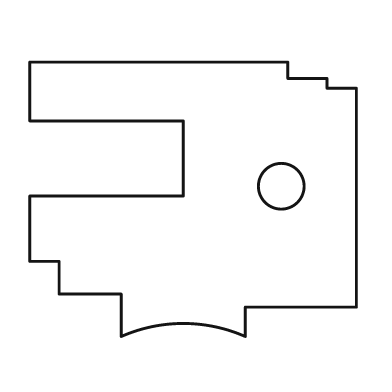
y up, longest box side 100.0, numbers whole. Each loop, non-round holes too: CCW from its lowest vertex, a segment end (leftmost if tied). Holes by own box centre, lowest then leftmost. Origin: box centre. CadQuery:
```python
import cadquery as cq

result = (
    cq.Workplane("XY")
    .moveTo(-22.0, -42.0)
    .threePointArc((-3.0, -38.0), (16.0, -42.0))
    .lineTo(16.0, -33.0)
    .lineTo(50.0, -33.0)
    .lineTo(50.0, 34.0)
    .lineTo(41.0, 34.0)
    .lineTo(41.0, 37.0)
    .lineTo(29.0, 37.0)
    .lineTo(29.0, 42.0)
    .lineTo(-50.0, 42.0)
    .lineTo(-50.0, 24.0)
    .lineTo(-3.0, 24.0)
    .lineTo(-3.0, 1.0)
    .lineTo(-50.0, 1.0)
    .lineTo(-50.0, -19.0)
    .lineTo(-41.0, -19.0)
    .lineTo(-41.0, -29.0)
    .lineTo(-22.0, -29.0)
    .close()
    .moveTo(27.0, 4.0)
    .circle(7.0)
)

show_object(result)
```